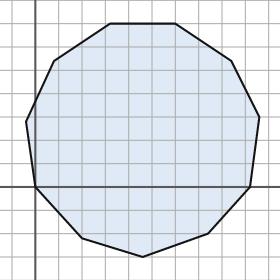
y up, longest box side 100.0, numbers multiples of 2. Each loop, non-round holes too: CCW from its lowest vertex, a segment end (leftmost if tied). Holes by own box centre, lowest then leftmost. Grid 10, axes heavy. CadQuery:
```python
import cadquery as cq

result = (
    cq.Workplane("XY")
    .moveTo(46.0, -30.0)
    .lineTo(74.0, -20.0)
    .lineTo(92.0, 0.0)
    .lineTo(96.0, 30.0)
    .lineTo(84.0, 54.0)
    .lineTo(60.0, 70.0)
    .lineTo(32.0, 70.0)
    .lineTo(8.0, 54.0)
    .lineTo(-4.0, 28.0)
    .lineTo(0.0, 0.0)
    .lineTo(20.0, -22.0)
    .close()
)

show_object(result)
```